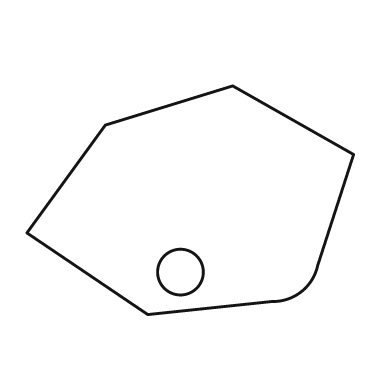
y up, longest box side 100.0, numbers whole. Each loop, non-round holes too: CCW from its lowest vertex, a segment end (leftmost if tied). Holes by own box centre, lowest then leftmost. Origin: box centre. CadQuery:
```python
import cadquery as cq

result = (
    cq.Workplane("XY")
    .moveTo(-13.0, -35.0)
    .lineTo(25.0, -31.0)
    .threePointArc((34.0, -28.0), (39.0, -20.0))
    .lineTo(50.0, 14.0)
    .lineTo(13.0, 35.0)
    .lineTo(-26.0, 23.0)
    .lineTo(-50.0, -10.0)
    .close()
    .moveTo(-3.0, -22.0)
    .circle(7.0)
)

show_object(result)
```